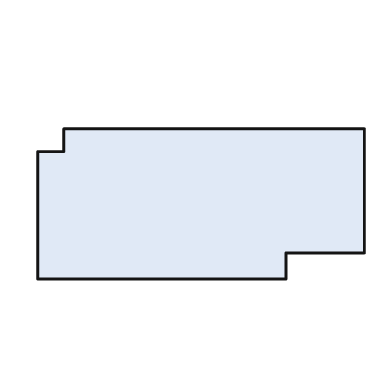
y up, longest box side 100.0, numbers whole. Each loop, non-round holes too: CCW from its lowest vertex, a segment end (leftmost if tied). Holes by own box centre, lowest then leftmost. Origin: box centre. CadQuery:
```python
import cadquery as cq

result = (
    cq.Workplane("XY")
    .moveTo(-50.0, -23.0)
    .lineTo(26.0, -23.0)
    .lineTo(26.0, -15.0)
    .lineTo(50.0, -15.0)
    .lineTo(50.0, 23.0)
    .lineTo(-42.0, 23.0)
    .lineTo(-42.0, 16.0)
    .lineTo(-50.0, 16.0)
    .close()
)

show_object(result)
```